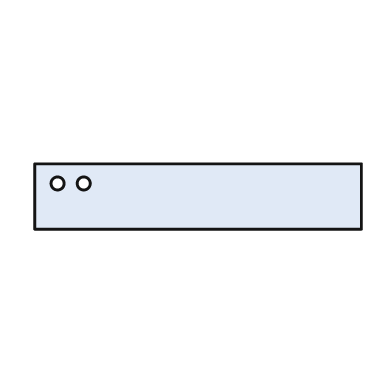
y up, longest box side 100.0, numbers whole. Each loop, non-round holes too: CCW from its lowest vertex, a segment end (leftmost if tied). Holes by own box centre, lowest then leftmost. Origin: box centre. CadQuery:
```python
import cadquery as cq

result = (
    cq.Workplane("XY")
    .moveTo(-50.0, -10.0)
    .lineTo(50.0, -10.0)
    .lineTo(50.0, 10.0)
    .lineTo(-50.0, 10.0)
    .close()
    .moveTo(-43.0, 4.0)
    .circle(2.0)
    .moveTo(-35.0, 4.0)
    .circle(2.0)
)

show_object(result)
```